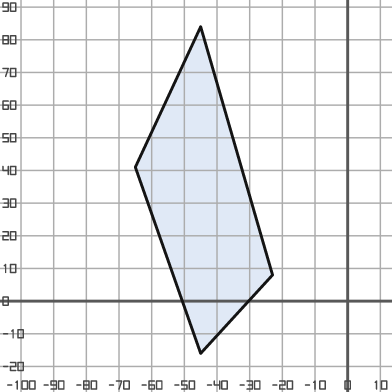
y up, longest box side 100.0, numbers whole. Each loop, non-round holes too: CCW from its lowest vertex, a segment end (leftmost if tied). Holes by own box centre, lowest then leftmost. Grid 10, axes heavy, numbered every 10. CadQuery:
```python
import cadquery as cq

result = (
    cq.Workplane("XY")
    .moveTo(-45.0, -16.0)
    .lineTo(-23.0, 8.0)
    .lineTo(-45.0, 84.0)
    .lineTo(-65.0, 41.0)
    .close()
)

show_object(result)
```